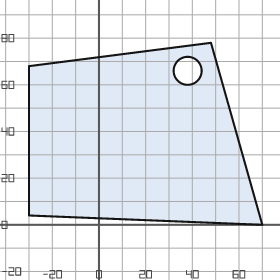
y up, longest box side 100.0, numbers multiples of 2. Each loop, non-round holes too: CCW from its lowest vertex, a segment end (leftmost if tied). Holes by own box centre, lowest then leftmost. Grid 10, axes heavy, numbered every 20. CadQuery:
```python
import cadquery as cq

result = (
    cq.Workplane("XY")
    .moveTo(70.0, 0.0)
    .lineTo(48.0, 78.0)
    .lineTo(-30.0, 68.0)
    .lineTo(-30.0, 4.0)
    .close()
    .moveTo(38.0, 66.0)
    .circle(6.0)
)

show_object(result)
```